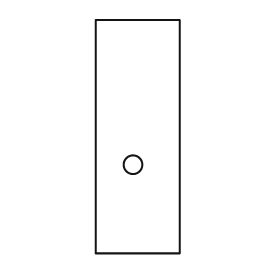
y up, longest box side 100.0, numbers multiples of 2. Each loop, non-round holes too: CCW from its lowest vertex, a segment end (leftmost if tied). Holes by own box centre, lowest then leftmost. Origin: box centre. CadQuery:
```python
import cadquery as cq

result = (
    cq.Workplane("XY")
    .moveTo(-18.0, -50.0)
    .lineTo(18.0, -50.0)
    .lineTo(18.0, 50.0)
    .lineTo(-18.0, 50.0)
    .close()
    .moveTo(-2.0, -12.0)
    .circle(4.0)
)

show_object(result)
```